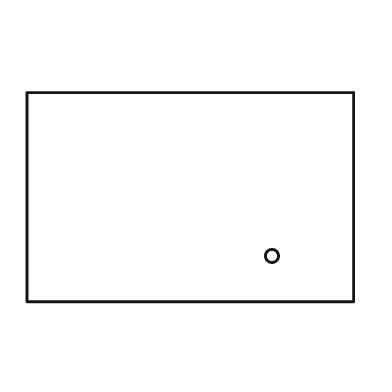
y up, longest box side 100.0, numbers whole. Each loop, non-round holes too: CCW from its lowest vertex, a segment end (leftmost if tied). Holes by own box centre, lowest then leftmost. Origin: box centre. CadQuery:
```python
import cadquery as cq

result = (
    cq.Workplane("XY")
    .moveTo(-50.0, -32.0)
    .lineTo(50.0, -32.0)
    .lineTo(50.0, 32.0)
    .lineTo(-50.0, 32.0)
    .close()
    .moveTo(25.0, -18.0)
    .circle(2.0)
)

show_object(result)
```